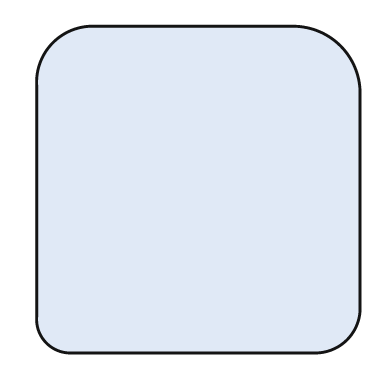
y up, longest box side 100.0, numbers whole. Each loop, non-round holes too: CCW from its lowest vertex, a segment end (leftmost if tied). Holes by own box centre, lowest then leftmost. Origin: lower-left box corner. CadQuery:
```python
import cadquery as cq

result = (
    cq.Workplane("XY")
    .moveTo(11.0, 0.0)
    .lineTo(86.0, 0.0)
    .threePointArc((95.0, 4.0), (99.0, 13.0))
    .lineTo(99.0, 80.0)
    .threePointArc((93.0, 94.0), (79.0, 100.0))
    .lineTo(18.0, 100.0)
    .threePointArc((5.0, 95.0), (0.0, 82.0))
    .lineTo(0.0, 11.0)
    .threePointArc((3.0, 3.0), (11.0, 0.0))
    .close()
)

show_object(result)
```